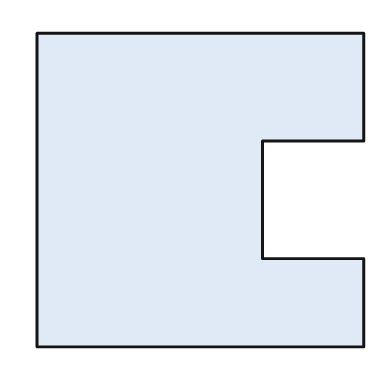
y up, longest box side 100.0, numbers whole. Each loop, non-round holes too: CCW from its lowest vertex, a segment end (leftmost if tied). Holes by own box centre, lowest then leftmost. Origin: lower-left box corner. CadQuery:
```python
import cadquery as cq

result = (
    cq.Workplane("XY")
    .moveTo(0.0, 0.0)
    .lineTo(100.0, 0.0)
    .lineTo(100.0, 27.0)
    .lineTo(69.0, 27.0)
    .lineTo(69.0, 63.0)
    .lineTo(100.0, 63.0)
    .lineTo(100.0, 96.0)
    .lineTo(0.0, 96.0)
    .close()
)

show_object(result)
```